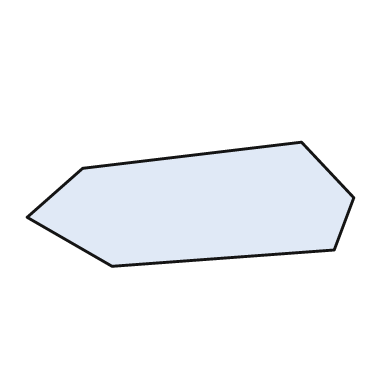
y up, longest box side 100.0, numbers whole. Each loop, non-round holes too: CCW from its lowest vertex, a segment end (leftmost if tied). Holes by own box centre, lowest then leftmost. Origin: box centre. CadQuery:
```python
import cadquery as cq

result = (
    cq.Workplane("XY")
    .moveTo(-24.0, -19.0)
    .lineTo(44.0, -14.0)
    .lineTo(50.0, 2.0)
    .lineTo(34.0, 19.0)
    .lineTo(-33.0, 11.0)
    .lineTo(-50.0, -4.0)
    .close()
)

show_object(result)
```